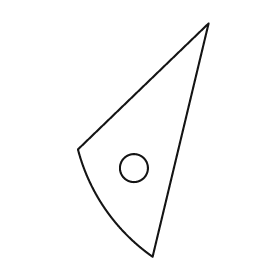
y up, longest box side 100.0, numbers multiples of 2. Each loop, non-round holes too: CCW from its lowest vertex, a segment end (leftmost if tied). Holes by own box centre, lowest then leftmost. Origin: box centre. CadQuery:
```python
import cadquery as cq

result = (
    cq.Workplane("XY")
    .moveTo(4.0, -50.0)
    .lineTo(28.0, 50.0)
    .lineTo(-28.0, -4.0)
    .threePointArc((-16.0, -30.0), (4.0, -50.0))
    .close()
    .moveTo(-4.0, -12.0)
    .circle(6.0)
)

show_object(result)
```